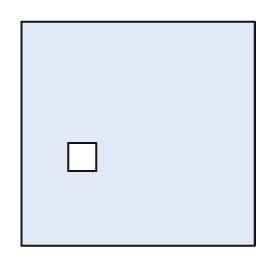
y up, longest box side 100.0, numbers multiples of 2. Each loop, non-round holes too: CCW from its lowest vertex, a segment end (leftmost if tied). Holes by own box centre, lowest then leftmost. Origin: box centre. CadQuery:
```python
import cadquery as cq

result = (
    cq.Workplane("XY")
    .moveTo(-50.0, -48.0)
    .lineTo(50.0, -48.0)
    .lineTo(50.0, 48.0)
    .lineTo(-50.0, 48.0)
    .close()
    .moveTo(-30.0, -16.0)
    .lineTo(-18.0, -16.0)
    .lineTo(-18.0, -4.0)
    .lineTo(-30.0, -4.0)
    .close()
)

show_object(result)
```